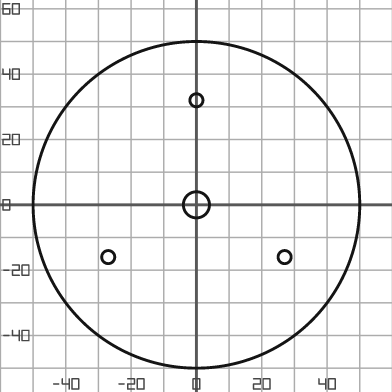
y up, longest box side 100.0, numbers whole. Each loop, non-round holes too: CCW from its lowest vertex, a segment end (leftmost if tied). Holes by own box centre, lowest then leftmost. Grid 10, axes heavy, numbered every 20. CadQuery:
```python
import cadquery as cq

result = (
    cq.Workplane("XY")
    .moveTo(0.0, 0.0)
    .circle(50.0)
    .moveTo(-27.0, -16.0)
    .circle(2.0)
    .moveTo(27.0, -16.0)
    .circle(2.0)
    .moveTo(0.0, 0.0)
    .circle(4.0)
    .moveTo(0.0, 32.0)
    .circle(2.0)
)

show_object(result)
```